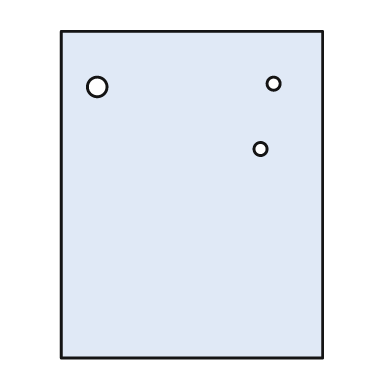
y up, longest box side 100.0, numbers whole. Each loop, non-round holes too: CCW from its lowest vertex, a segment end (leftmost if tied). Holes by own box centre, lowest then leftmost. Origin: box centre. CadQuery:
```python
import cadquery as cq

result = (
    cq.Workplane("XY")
    .moveTo(-40.0, -50.0)
    .lineTo(40.0, -50.0)
    .lineTo(40.0, 50.0)
    .lineTo(-40.0, 50.0)
    .close()
    .moveTo(21.0, 14.0)
    .circle(2.0)
    .moveTo(-29.0, 33.0)
    .circle(3.0)
    .moveTo(25.0, 34.0)
    .circle(2.0)
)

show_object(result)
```